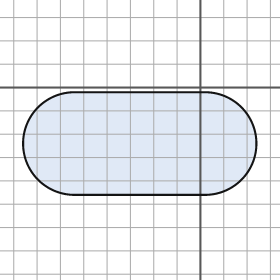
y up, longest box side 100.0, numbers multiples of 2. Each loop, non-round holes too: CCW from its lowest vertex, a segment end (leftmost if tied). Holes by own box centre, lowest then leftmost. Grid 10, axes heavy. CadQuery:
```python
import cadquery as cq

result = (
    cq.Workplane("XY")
    .moveTo(-54.0, -46.0)
    .lineTo(2.0, -46.0)
    .threePointArc((24.0, -24.0), (2.0, -2.0))
    .lineTo(-54.0, -2.0)
    .threePointArc((-76.0, -24.0), (-54.0, -46.0))
    .close()
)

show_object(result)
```